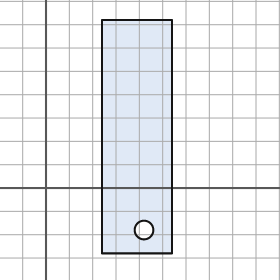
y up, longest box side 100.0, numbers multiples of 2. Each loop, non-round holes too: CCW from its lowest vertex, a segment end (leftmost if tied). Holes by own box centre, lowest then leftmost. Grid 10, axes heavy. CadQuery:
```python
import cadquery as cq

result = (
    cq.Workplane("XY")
    .moveTo(24.0, -28.0)
    .lineTo(54.0, -28.0)
    .lineTo(54.0, 72.0)
    .lineTo(24.0, 72.0)
    .close()
    .moveTo(42.0, -18.0)
    .circle(4.0)
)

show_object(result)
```